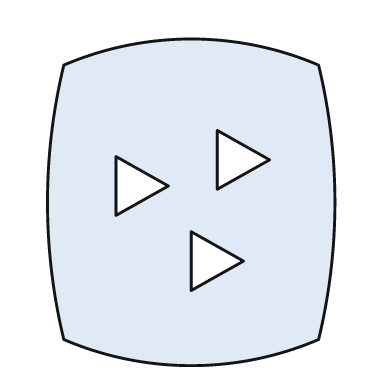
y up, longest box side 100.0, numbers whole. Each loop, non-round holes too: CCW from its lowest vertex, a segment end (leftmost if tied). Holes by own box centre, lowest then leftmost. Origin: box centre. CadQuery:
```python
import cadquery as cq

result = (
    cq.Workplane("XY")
    .moveTo(-39.0, -42.0)
    .threePointArc((0.0, -50.0), (39.0, -42.0))
    .threePointArc((44.0, 0.0), (39.0, 42.0))
    .threePointArc((0.0, 50.0), (-39.0, 42.0))
    .threePointArc((-44.0, 0.0), (-39.0, -42.0))
    .close()
    .moveTo(0.0, -27.0)
    .lineTo(16.0, -18.0)
    .lineTo(0.0, -9.0)
    .close()
    .moveTo(-23.0, -4.0)
    .lineTo(-7.0, 5.0)
    .lineTo(-23.0, 14.0)
    .close()
    .moveTo(8.0, 4.0)
    .lineTo(24.0, 13.0)
    .lineTo(8.0, 22.0)
    .close()
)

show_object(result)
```